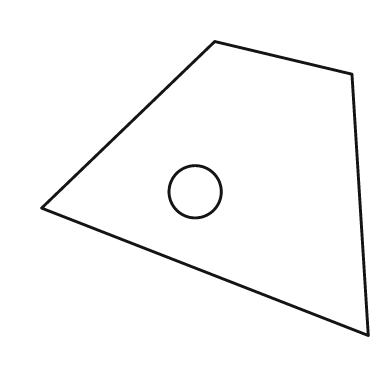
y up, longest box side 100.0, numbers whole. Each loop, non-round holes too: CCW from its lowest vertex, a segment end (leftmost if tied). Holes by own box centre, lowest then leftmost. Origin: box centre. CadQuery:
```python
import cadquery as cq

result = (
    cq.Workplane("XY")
    .moveTo(50.0, -45.0)
    .lineTo(45.0, 35.0)
    .lineTo(3.0, 45.0)
    .lineTo(-50.0, -6.0)
    .close()
    .moveTo(-3.0, -1.0)
    .circle(8.0)
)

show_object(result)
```